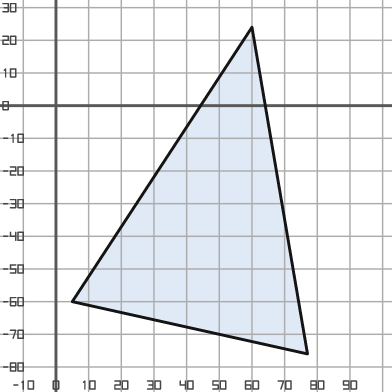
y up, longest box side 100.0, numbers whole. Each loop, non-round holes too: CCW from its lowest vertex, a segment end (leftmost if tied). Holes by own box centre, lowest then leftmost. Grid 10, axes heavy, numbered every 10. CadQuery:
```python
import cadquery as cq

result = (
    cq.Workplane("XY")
    .moveTo(77.0, -76.0)
    .lineTo(60.0, 24.0)
    .lineTo(5.0, -60.0)
    .close()
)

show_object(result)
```